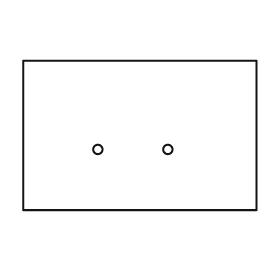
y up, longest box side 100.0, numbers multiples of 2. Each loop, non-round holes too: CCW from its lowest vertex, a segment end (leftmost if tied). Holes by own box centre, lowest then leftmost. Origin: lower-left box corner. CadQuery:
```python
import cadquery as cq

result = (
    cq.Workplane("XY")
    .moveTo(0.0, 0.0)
    .lineTo(100.0, 0.0)
    .lineTo(100.0, 64.0)
    .lineTo(0.0, 64.0)
    .close()
    .moveTo(32.0, 26.0)
    .circle(2.0)
    .moveTo(62.0, 26.0)
    .circle(2.0)
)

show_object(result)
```